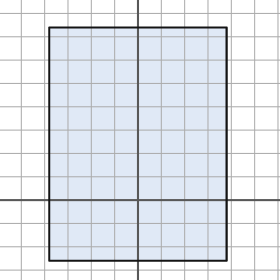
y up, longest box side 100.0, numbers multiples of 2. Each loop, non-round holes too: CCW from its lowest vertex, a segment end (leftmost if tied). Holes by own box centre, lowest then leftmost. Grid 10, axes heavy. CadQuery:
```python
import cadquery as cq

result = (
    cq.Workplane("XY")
    .moveTo(-38.0, -26.0)
    .lineTo(38.0, -26.0)
    .lineTo(38.0, 74.0)
    .lineTo(-38.0, 74.0)
    .close()
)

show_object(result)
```